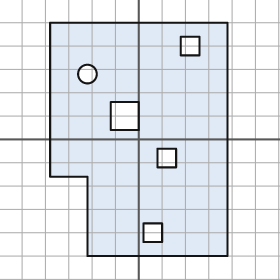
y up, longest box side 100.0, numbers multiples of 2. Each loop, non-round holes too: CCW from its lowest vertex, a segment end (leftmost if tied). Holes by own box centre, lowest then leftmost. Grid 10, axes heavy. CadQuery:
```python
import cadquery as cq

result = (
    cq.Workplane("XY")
    .moveTo(-22.0, -50.0)
    .lineTo(38.0, -50.0)
    .lineTo(38.0, 50.0)
    .lineTo(-38.0, 50.0)
    .lineTo(-38.0, -16.0)
    .lineTo(-22.0, -16.0)
    .close()
    .moveTo(2.0, -44.0)
    .lineTo(10.0, -44.0)
    .lineTo(10.0, -36.0)
    .lineTo(2.0, -36.0)
    .close()
    .moveTo(8.0, -12.0)
    .lineTo(16.0, -12.0)
    .lineTo(16.0, -4.0)
    .lineTo(8.0, -4.0)
    .close()
    .moveTo(-12.0, 4.0)
    .lineTo(0.0, 4.0)
    .lineTo(0.0, 16.0)
    .lineTo(-12.0, 16.0)
    .close()
    .moveTo(-22.0, 28.0)
    .circle(4.0)
    .moveTo(18.0, 36.0)
    .lineTo(26.0, 36.0)
    .lineTo(26.0, 44.0)
    .lineTo(18.0, 44.0)
    .close()
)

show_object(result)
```